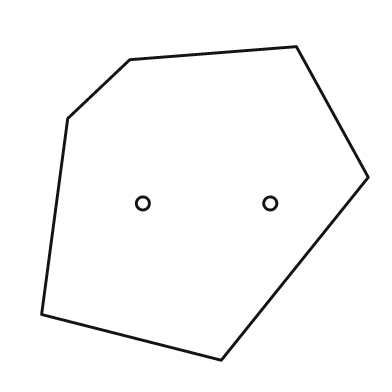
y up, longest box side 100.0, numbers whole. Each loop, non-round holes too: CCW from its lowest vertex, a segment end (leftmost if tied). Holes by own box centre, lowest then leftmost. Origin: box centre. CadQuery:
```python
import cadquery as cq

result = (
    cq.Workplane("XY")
    .moveTo(5.0, -48.0)
    .lineTo(50.0, 8.0)
    .lineTo(28.0, 48.0)
    .lineTo(-23.0, 44.0)
    .lineTo(-42.0, 26.0)
    .lineTo(-50.0, -34.0)
    .close()
    .moveTo(-19.0, 0.0)
    .circle(2.0)
    .moveTo(20.0, 0.0)
    .circle(2.0)
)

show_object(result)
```